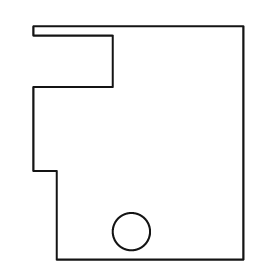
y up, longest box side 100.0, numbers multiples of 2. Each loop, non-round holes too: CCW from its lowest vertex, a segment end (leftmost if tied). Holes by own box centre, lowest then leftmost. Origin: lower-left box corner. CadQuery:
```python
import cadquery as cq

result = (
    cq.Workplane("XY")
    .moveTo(10.0, 0.0)
    .lineTo(90.0, 0.0)
    .lineTo(90.0, 100.0)
    .lineTo(0.0, 100.0)
    .lineTo(0.0, 96.0)
    .lineTo(34.0, 96.0)
    .lineTo(34.0, 74.0)
    .lineTo(0.0, 74.0)
    .lineTo(0.0, 38.0)
    .lineTo(10.0, 38.0)
    .close()
    .moveTo(42.0, 12.0)
    .circle(8.0)
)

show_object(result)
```